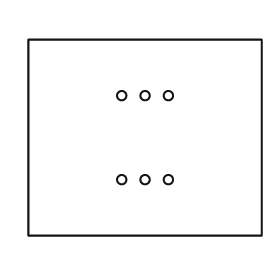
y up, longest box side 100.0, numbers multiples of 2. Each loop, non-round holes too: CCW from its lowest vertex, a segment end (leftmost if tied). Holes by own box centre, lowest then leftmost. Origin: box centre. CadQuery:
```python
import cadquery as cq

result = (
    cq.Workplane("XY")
    .moveTo(-50.0, -42.0)
    .lineTo(50.0, -42.0)
    .lineTo(50.0, 42.0)
    .lineTo(-50.0, 42.0)
    .close()
    .moveTo(-10.0, -18.0)
    .circle(2.0)
    .moveTo(0.0, -18.0)
    .circle(2.0)
    .moveTo(10.0, -18.0)
    .circle(2.0)
    .moveTo(-10.0, 18.0)
    .circle(2.0)
    .moveTo(0.0, 18.0)
    .circle(2.0)
    .moveTo(10.0, 18.0)
    .circle(2.0)
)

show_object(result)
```